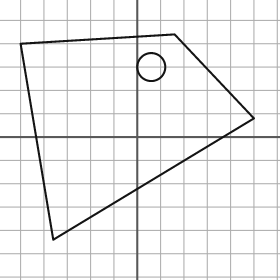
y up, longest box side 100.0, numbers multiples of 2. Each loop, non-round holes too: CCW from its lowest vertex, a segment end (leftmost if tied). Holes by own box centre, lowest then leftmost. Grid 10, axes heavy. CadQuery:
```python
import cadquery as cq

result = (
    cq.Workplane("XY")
    .moveTo(-36.0, -44.0)
    .lineTo(50.0, 8.0)
    .lineTo(16.0, 44.0)
    .lineTo(-50.0, 40.0)
    .close()
    .moveTo(6.0, 30.0)
    .circle(6.0)
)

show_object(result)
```